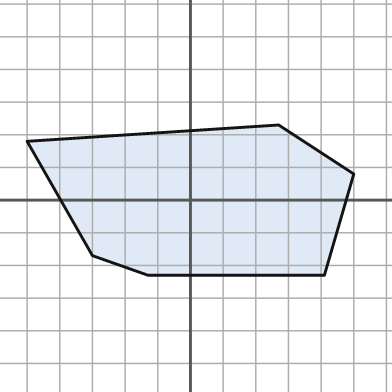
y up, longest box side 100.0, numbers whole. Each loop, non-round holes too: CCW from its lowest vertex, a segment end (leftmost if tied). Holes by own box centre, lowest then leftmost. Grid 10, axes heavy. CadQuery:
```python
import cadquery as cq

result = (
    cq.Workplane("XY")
    .moveTo(-13.0, -23.0)
    .lineTo(41.0, -23.0)
    .lineTo(50.0, 8.0)
    .lineTo(27.0, 23.0)
    .lineTo(-50.0, 18.0)
    .lineTo(-30.0, -17.0)
    .close()
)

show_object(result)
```